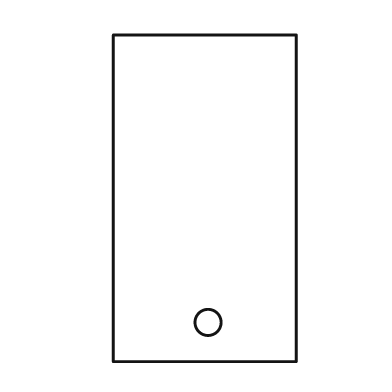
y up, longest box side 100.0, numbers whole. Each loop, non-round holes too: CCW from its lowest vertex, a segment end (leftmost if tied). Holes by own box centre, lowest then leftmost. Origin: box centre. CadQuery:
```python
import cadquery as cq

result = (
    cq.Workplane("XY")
    .moveTo(-28.0, -50.0)
    .lineTo(28.0, -50.0)
    .lineTo(28.0, 50.0)
    .lineTo(-28.0, 50.0)
    .close()
    .moveTo(1.0, -38.0)
    .circle(4.0)
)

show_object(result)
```